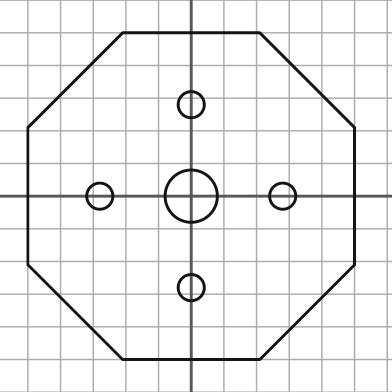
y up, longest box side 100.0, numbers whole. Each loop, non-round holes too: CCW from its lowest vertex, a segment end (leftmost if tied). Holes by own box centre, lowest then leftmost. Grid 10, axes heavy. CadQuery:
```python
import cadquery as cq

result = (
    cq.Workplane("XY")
    .moveTo(-21.0, -50.0)
    .lineTo(21.0, -50.0)
    .lineTo(50.0, -21.0)
    .lineTo(50.0, 21.0)
    .lineTo(21.0, 50.0)
    .lineTo(-21.0, 50.0)
    .lineTo(-50.0, 21.0)
    .lineTo(-50.0, -21.0)
    .close()
    .moveTo(0.0, -28.0)
    .circle(4.0)
    .moveTo(-28.0, 0.0)
    .circle(4.0)
    .moveTo(0.0, 0.0)
    .circle(8.0)
    .moveTo(28.0, 0.0)
    .circle(4.0)
    .moveTo(0.0, 28.0)
    .circle(4.0)
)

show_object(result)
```